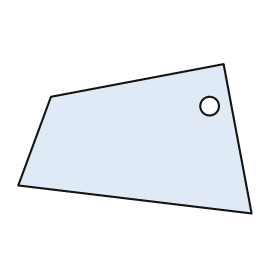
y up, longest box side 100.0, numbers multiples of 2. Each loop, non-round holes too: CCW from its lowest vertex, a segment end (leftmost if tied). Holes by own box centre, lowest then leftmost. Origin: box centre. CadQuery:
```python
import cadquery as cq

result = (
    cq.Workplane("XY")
    .moveTo(50.0, -32.0)
    .lineTo(38.0, 32.0)
    .lineTo(-36.0, 18.0)
    .lineTo(-50.0, -20.0)
    .close()
    .moveTo(32.0, 14.0)
    .circle(4.0)
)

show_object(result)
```